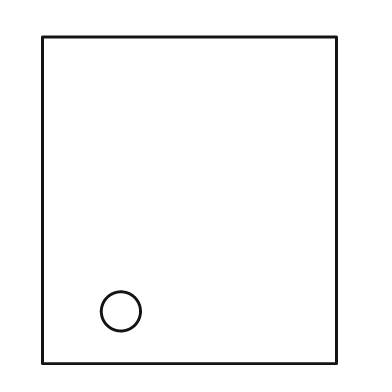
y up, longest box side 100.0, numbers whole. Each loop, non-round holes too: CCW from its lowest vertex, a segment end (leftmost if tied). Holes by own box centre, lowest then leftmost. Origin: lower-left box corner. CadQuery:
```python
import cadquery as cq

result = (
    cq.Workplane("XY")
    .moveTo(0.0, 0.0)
    .lineTo(90.0, 0.0)
    .lineTo(90.0, 100.0)
    .lineTo(0.0, 100.0)
    .close()
    .moveTo(24.0, 16.0)
    .circle(6.0)
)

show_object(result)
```